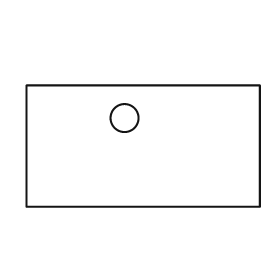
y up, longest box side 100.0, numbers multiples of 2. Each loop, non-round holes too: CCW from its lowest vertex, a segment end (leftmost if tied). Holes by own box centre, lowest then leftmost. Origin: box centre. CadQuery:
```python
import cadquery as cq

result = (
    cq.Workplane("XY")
    .moveTo(-50.0, -26.0)
    .lineTo(50.0, -26.0)
    .lineTo(50.0, 26.0)
    .lineTo(-50.0, 26.0)
    .close()
    .moveTo(-8.0, 12.0)
    .circle(6.0)
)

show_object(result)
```